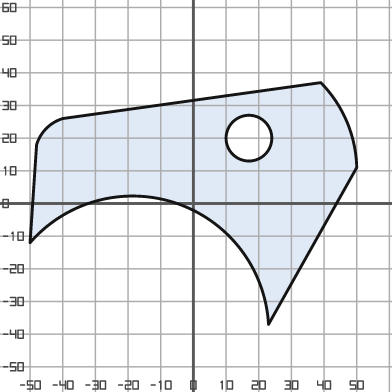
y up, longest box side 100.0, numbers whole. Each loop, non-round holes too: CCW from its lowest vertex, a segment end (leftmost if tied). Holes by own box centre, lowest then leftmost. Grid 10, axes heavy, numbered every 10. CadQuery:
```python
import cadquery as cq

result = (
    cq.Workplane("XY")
    .moveTo(23.0, -37.0)
    .lineTo(50.0, 11.0)
    .threePointArc((47.0, 25.0), (39.0, 37.0))
    .lineTo(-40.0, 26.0)
    .threePointArc((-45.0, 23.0), (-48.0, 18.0))
    .lineTo(-50.0, -12.0)
    .threePointArc((-5.0, 0.0), (23.0, -37.0))
    .close()
    .moveTo(17.0, 20.0)
    .circle(7.0)
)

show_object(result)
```